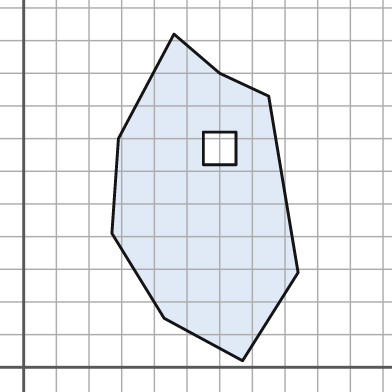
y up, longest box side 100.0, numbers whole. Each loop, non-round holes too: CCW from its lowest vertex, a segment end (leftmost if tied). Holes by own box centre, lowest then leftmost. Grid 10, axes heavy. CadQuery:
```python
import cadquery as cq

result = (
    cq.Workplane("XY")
    .moveTo(67.0, 2.0)
    .lineTo(84.0, 29.0)
    .lineTo(75.0, 83.0)
    .lineTo(60.0, 90.0)
    .lineTo(46.0, 102.0)
    .lineTo(29.0, 70.0)
    .lineTo(27.0, 41.0)
    .lineTo(43.0, 15.0)
    .close()
    .moveTo(55.0, 62.0)
    .lineTo(65.0, 62.0)
    .lineTo(65.0, 72.0)
    .lineTo(55.0, 72.0)
    .close()
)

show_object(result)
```